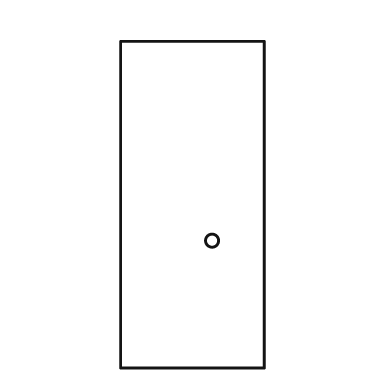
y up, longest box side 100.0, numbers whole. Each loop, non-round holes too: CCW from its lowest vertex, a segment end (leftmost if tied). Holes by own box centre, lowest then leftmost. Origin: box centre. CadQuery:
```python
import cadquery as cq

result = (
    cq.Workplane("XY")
    .moveTo(-22.0, -50.0)
    .lineTo(22.0, -50.0)
    .lineTo(22.0, 50.0)
    .lineTo(-22.0, 50.0)
    .close()
    .moveTo(6.0, -11.0)
    .circle(2.0)
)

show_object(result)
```